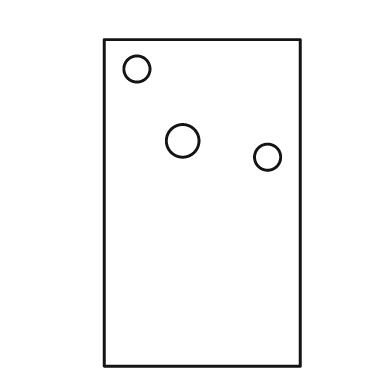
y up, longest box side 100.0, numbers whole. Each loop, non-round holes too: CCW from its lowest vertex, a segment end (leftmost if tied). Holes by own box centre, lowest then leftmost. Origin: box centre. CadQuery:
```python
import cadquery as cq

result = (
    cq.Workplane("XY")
    .moveTo(-30.0, -50.0)
    .lineTo(30.0, -50.0)
    .lineTo(30.0, 50.0)
    .lineTo(-30.0, 50.0)
    .close()
    .moveTo(20.0, 14.0)
    .circle(4.0)
    .moveTo(-6.0, 19.0)
    .circle(5.0)
    .moveTo(-20.0, 41.0)
    .circle(4.0)
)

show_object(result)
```